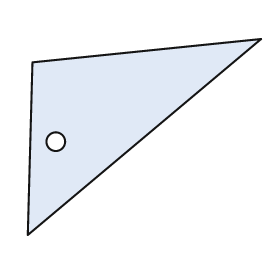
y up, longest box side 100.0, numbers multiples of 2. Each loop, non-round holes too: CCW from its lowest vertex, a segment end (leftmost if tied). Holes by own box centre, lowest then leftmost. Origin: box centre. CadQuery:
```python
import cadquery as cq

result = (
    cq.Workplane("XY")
    .moveTo(-50.0, -42.0)
    .lineTo(50.0, 42.0)
    .lineTo(-48.0, 32.0)
    .close()
    .moveTo(-38.0, -2.0)
    .circle(4.0)
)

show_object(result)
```